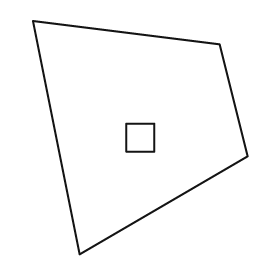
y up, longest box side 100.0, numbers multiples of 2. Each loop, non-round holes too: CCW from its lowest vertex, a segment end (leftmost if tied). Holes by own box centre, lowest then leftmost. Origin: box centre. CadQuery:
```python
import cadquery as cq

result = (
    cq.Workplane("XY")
    .moveTo(-26.0, -50.0)
    .lineTo(46.0, -8.0)
    .lineTo(34.0, 40.0)
    .lineTo(-46.0, 50.0)
    .close()
    .moveTo(-6.0, -6.0)
    .lineTo(6.0, -6.0)
    .lineTo(6.0, 6.0)
    .lineTo(-6.0, 6.0)
    .close()
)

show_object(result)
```